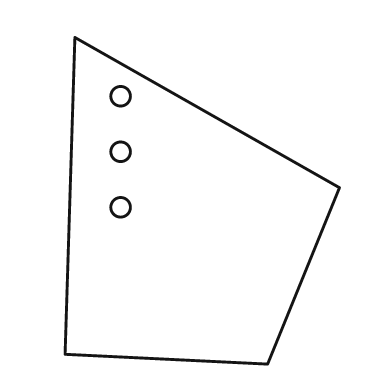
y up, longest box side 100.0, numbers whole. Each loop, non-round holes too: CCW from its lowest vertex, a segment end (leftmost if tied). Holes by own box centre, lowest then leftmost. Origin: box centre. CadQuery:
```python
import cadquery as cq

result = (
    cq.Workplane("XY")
    .moveTo(20.0, -50.0)
    .lineTo(42.0, 4.0)
    .lineTo(-39.0, 50.0)
    .lineTo(-42.0, -47.0)
    .close()
    .moveTo(-25.0, -2.0)
    .circle(3.0)
    .moveTo(-25.0, 15.0)
    .circle(3.0)
    .moveTo(-25.0, 32.0)
    .circle(3.0)
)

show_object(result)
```